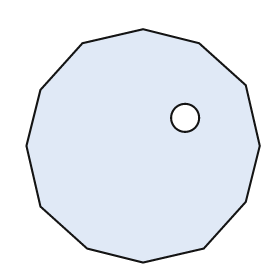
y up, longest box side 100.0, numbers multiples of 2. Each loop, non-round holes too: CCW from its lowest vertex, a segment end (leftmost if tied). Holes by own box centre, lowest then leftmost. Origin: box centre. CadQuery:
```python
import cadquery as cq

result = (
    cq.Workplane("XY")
    .moveTo(0.0, -50.0)
    .lineTo(26.0, -44.0)
    .lineTo(44.0, -24.0)
    .lineTo(50.0, 0.0)
    .lineTo(44.0, 26.0)
    .lineTo(24.0, 44.0)
    .lineTo(0.0, 50.0)
    .lineTo(-26.0, 44.0)
    .lineTo(-44.0, 24.0)
    .lineTo(-50.0, 0.0)
    .lineTo(-44.0, -26.0)
    .lineTo(-24.0, -44.0)
    .close()
    .moveTo(18.0, 12.0)
    .circle(6.0)
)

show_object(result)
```